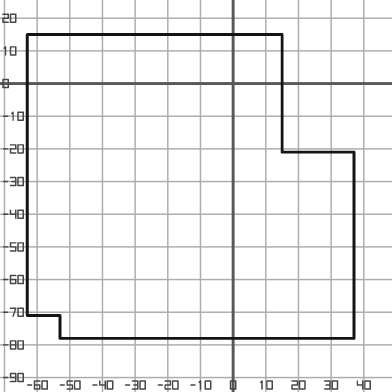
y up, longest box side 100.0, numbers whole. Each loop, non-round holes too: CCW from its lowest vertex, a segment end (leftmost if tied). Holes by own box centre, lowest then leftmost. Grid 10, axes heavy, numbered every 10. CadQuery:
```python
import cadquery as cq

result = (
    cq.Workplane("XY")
    .moveTo(-53.0, -78.0)
    .lineTo(37.0, -78.0)
    .lineTo(37.0, -21.0)
    .lineTo(15.0, -21.0)
    .lineTo(15.0, 15.0)
    .lineTo(-63.0, 15.0)
    .lineTo(-63.0, -71.0)
    .lineTo(-53.0, -71.0)
    .close()
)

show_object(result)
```